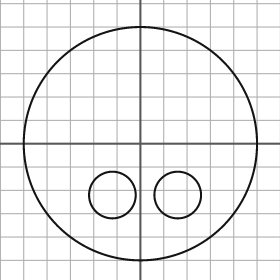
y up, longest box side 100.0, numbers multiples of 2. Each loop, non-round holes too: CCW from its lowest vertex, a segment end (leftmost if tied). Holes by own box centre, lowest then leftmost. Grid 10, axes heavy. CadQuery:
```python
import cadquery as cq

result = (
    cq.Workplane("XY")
    .moveTo(0.0, 0.0)
    .circle(50.0)
    .moveTo(-12.0, -22.0)
    .circle(10.0)
    .moveTo(16.0, -22.0)
    .circle(10.0)
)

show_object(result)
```